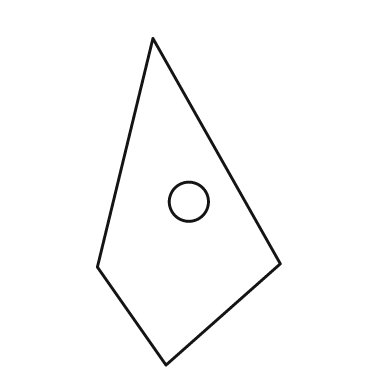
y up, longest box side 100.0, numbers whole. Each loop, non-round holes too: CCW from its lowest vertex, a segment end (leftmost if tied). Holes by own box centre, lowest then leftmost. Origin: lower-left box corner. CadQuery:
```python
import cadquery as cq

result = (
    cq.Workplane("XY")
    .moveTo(21.0, 0.0)
    .lineTo(56.0, 31.0)
    .lineTo(17.0, 100.0)
    .lineTo(0.0, 30.0)
    .close()
    .moveTo(28.0, 50.0)
    .circle(6.0)
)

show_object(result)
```